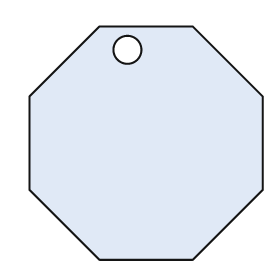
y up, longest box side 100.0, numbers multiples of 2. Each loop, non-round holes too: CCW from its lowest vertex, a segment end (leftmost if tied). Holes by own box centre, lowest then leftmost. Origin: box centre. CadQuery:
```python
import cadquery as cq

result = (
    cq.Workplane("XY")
    .moveTo(-20.0, -50.0)
    .lineTo(20.0, -50.0)
    .lineTo(50.0, -20.0)
    .lineTo(50.0, 20.0)
    .lineTo(20.0, 50.0)
    .lineTo(-20.0, 50.0)
    .lineTo(-50.0, 20.0)
    .lineTo(-50.0, -20.0)
    .close()
    .moveTo(-8.0, 40.0)
    .circle(6.0)
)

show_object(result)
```